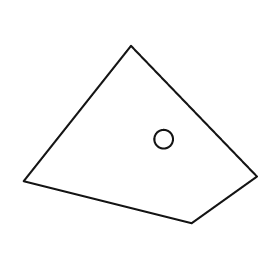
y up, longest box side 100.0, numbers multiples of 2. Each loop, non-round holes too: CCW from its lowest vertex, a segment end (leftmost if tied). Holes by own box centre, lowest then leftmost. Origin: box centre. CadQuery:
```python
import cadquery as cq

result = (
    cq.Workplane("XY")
    .moveTo(22.0, -38.0)
    .lineTo(50.0, -18.0)
    .lineTo(-4.0, 38.0)
    .lineTo(-50.0, -20.0)
    .close()
    .moveTo(10.0, -2.0)
    .circle(4.0)
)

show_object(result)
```